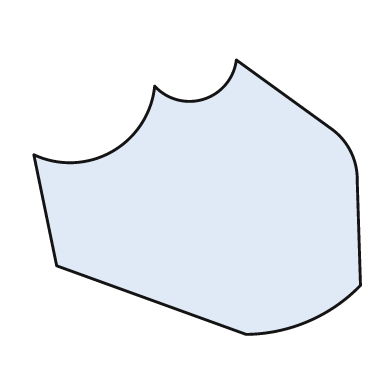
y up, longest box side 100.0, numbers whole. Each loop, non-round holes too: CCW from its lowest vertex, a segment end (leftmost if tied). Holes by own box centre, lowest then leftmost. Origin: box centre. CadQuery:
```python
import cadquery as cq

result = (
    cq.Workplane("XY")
    .moveTo(15.0, -42.0)
    .threePointArc((34.0, -38.0), (50.0, -27.0))
    .lineTo(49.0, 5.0)
    .threePointArc((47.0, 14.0), (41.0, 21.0))
    .lineTo(12.0, 42.0)
    .threePointArc((2.0, 30.0), (-13.0, 34.0))
    .threePointArc((-26.0, 14.0), (-50.0, 13.0))
    .lineTo(-43.0, -21.0)
    .close()
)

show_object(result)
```